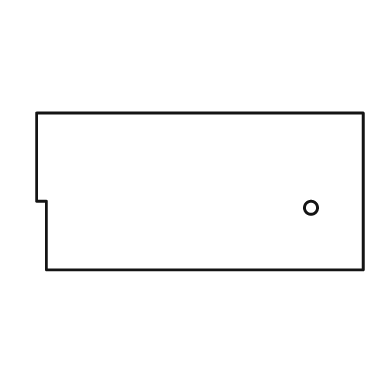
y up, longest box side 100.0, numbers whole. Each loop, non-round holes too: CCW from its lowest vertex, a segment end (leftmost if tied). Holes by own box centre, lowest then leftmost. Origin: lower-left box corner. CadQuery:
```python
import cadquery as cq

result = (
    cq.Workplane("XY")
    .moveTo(3.0, 0.0)
    .lineTo(100.0, 0.0)
    .lineTo(100.0, 48.0)
    .lineTo(0.0, 48.0)
    .lineTo(0.0, 21.0)
    .lineTo(3.0, 21.0)
    .close()
    .moveTo(84.0, 19.0)
    .circle(2.0)
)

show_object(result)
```